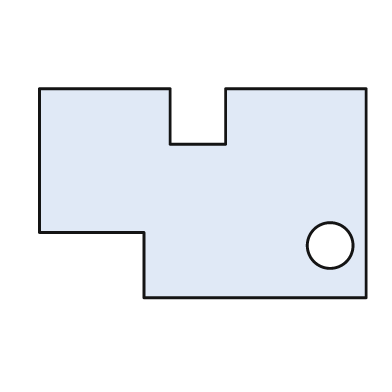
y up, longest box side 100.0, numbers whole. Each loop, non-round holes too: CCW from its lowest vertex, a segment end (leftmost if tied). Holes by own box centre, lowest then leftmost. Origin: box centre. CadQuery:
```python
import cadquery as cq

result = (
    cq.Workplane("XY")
    .moveTo(-18.0, -32.0)
    .lineTo(50.0, -32.0)
    .lineTo(50.0, 32.0)
    .lineTo(7.0, 32.0)
    .lineTo(7.0, 15.0)
    .lineTo(-10.0, 15.0)
    .lineTo(-10.0, 32.0)
    .lineTo(-50.0, 32.0)
    .lineTo(-50.0, -12.0)
    .lineTo(-18.0, -12.0)
    .close()
    .moveTo(39.0, -16.0)
    .circle(7.0)
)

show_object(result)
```